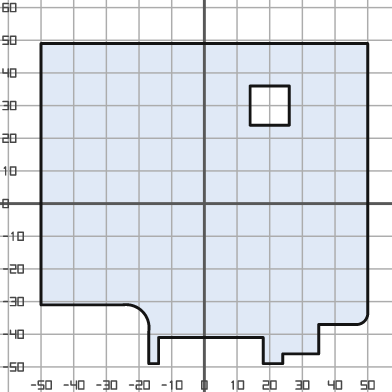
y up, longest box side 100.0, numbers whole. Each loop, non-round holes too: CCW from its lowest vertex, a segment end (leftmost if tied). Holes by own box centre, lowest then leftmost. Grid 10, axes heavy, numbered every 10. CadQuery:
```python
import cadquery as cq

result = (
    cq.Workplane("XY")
    .moveTo(-17.0, -49.0)
    .lineTo(-14.0, -49.0)
    .lineTo(-14.0, -41.0)
    .lineTo(18.0, -41.0)
    .lineTo(18.0, -49.0)
    .lineTo(24.0, -49.0)
    .lineTo(24.0, -46.0)
    .lineTo(35.0, -46.0)
    .lineTo(35.0, -37.0)
    .lineTo(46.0, -37.0)
    .threePointArc((49.0, -36.0), (50.0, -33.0))
    .lineTo(50.0, 49.0)
    .lineTo(-50.0, 49.0)
    .lineTo(-50.0, -31.0)
    .lineTo(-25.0, -31.0)
    .threePointArc((-19.0, -33.0), (-17.0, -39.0))
    .close()
    .moveTo(14.0, 24.0)
    .lineTo(26.0, 24.0)
    .lineTo(26.0, 36.0)
    .lineTo(14.0, 36.0)
    .close()
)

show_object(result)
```